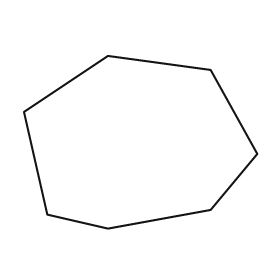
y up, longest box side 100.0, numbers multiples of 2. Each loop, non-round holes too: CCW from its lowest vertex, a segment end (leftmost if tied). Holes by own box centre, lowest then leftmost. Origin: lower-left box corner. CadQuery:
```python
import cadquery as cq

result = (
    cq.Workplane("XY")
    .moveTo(36.0, 0.0)
    .lineTo(80.0, 8.0)
    .lineTo(100.0, 32.0)
    .lineTo(80.0, 68.0)
    .lineTo(36.0, 74.0)
    .lineTo(0.0, 50.0)
    .lineTo(10.0, 6.0)
    .close()
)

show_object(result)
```